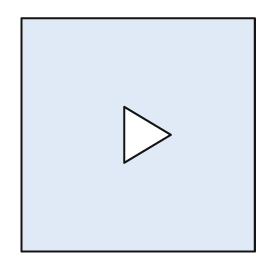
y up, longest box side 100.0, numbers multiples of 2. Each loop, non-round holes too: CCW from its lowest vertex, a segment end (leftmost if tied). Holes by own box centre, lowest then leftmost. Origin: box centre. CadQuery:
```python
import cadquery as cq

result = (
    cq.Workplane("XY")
    .moveTo(-50.0, -50.0)
    .lineTo(50.0, -50.0)
    .lineTo(50.0, 50.0)
    .lineTo(-50.0, 50.0)
    .close()
    .moveTo(-6.0, -12.0)
    .lineTo(14.0, 0.0)
    .lineTo(-6.0, 12.0)
    .close()
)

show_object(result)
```